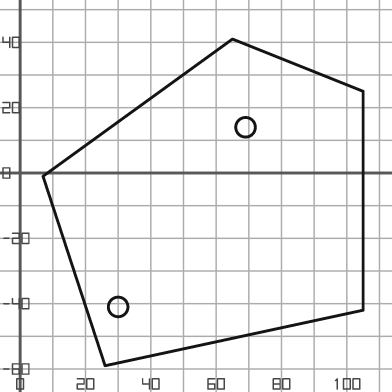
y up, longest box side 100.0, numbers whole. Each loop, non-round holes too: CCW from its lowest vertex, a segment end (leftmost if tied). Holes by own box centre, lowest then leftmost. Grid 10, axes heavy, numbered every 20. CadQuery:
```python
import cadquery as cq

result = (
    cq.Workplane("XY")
    .moveTo(26.0, -59.0)
    .lineTo(105.0, -42.0)
    .lineTo(105.0, 25.0)
    .lineTo(65.0, 41.0)
    .lineTo(7.0, -1.0)
    .close()
    .moveTo(30.0, -41.0)
    .circle(3.0)
    .moveTo(69.0, 14.0)
    .circle(3.0)
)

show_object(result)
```